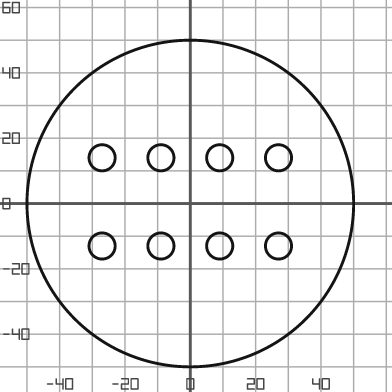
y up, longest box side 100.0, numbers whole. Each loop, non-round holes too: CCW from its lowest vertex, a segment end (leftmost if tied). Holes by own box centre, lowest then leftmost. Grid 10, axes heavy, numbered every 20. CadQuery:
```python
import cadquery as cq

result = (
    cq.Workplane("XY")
    .moveTo(0.0, 0.0)
    .circle(50.0)
    .moveTo(-27.0, -13.0)
    .circle(4.0)
    .moveTo(-9.0, -13.0)
    .circle(4.0)
    .moveTo(9.0, -13.0)
    .circle(4.0)
    .moveTo(27.0, -13.0)
    .circle(4.0)
    .moveTo(-27.0, 14.0)
    .circle(4.0)
    .moveTo(-9.0, 14.0)
    .circle(4.0)
    .moveTo(9.0, 14.0)
    .circle(4.0)
    .moveTo(27.0, 14.0)
    .circle(4.0)
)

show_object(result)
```